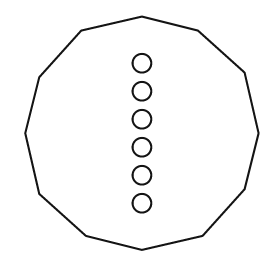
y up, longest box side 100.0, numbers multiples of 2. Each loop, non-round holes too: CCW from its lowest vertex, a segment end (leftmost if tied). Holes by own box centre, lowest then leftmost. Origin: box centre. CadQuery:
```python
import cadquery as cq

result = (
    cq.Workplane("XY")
    .moveTo(0.0, -50.0)
    .lineTo(26.0, -44.0)
    .lineTo(44.0, -24.0)
    .lineTo(50.0, 0.0)
    .lineTo(44.0, 26.0)
    .lineTo(24.0, 44.0)
    .lineTo(0.0, 50.0)
    .lineTo(-26.0, 44.0)
    .lineTo(-44.0, 24.0)
    .lineTo(-50.0, 0.0)
    .lineTo(-44.0, -26.0)
    .lineTo(-24.0, -44.0)
    .close()
    .moveTo(0.0, -30.0)
    .circle(4.0)
    .moveTo(0.0, -18.0)
    .circle(4.0)
    .moveTo(0.0, -6.0)
    .circle(4.0)
    .moveTo(0.0, 6.0)
    .circle(4.0)
    .moveTo(0.0, 18.0)
    .circle(4.0)
    .moveTo(0.0, 30.0)
    .circle(4.0)
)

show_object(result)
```